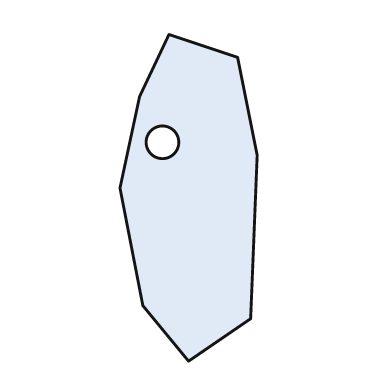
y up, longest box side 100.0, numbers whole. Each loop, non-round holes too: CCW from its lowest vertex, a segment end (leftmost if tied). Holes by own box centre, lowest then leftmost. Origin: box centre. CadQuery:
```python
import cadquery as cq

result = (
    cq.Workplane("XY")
    .moveTo(0.0, -50.0)
    .lineTo(19.0, -37.0)
    .lineTo(21.0, 13.0)
    .lineTo(15.0, 43.0)
    .lineTo(-6.0, 50.0)
    .lineTo(-15.0, 31.0)
    .lineTo(-21.0, 3.0)
    .lineTo(-14.0, -33.0)
    .close()
    .moveTo(-8.0, 17.0)
    .circle(5.0)
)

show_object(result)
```